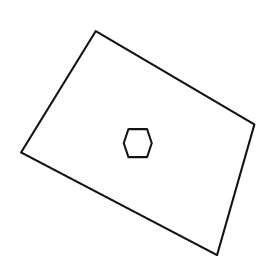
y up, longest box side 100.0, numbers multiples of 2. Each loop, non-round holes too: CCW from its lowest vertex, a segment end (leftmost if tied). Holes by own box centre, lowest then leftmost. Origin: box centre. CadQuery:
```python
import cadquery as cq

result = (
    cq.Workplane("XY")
    .moveTo(34.0, -48.0)
    .lineTo(50.0, 8.0)
    .lineTo(-18.0, 48.0)
    .lineTo(-50.0, -4.0)
    .close()
    .moveTo(-4.0, -6.0)
    .lineTo(4.0, -6.0)
    .lineTo(6.0, 0.0)
    .lineTo(4.0, 6.0)
    .lineTo(-4.0, 6.0)
    .lineTo(-6.0, 0.0)
    .close()
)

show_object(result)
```